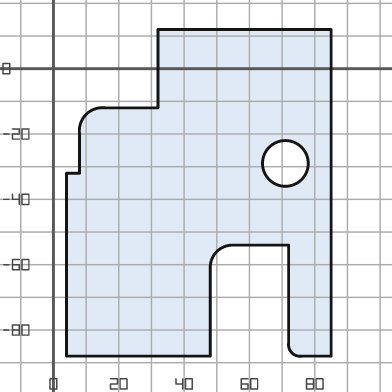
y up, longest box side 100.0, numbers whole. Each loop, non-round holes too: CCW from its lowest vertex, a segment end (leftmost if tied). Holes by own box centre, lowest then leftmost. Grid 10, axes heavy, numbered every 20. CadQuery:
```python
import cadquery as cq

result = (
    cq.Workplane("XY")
    .moveTo(4.0, -88.0)
    .lineTo(48.0, -88.0)
    .lineTo(48.0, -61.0)
    .threePointArc((50.0, -56.0), (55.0, -54.0))
    .lineTo(72.0, -54.0)
    .lineTo(72.0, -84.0)
    .threePointArc((73.0, -87.0), (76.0, -88.0))
    .lineTo(85.0, -88.0)
    .lineTo(85.0, 12.0)
    .lineTo(32.0, 12.0)
    .lineTo(32.0, -12.0)
    .lineTo(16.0, -12.0)
    .threePointArc((10.0, -14.0), (8.0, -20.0))
    .lineTo(8.0, -32.0)
    .lineTo(4.0, -32.0)
    .close()
    .moveTo(71.0, -29.0)
    .circle(7.0)
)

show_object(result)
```